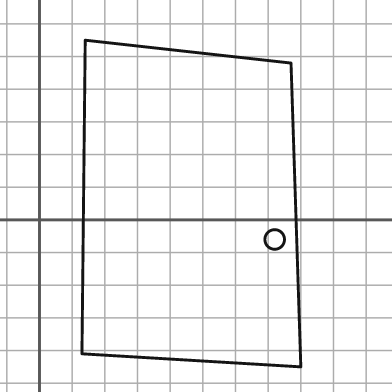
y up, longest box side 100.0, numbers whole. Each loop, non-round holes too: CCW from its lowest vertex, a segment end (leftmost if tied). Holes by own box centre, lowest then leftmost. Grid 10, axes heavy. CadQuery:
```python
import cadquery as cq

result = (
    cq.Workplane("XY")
    .moveTo(80.0, -45.0)
    .lineTo(77.0, 48.0)
    .lineTo(14.0, 55.0)
    .lineTo(13.0, -41.0)
    .close()
    .moveTo(72.0, -6.0)
    .circle(3.0)
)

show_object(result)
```